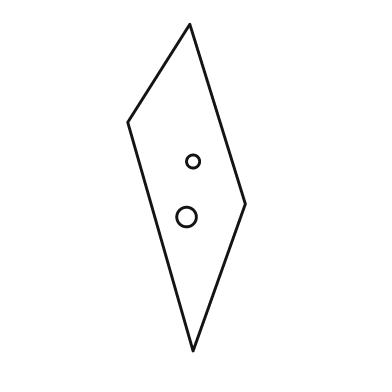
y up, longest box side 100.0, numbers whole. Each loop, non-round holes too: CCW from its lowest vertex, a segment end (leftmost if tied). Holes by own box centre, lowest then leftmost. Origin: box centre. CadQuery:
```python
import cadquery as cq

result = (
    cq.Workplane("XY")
    .moveTo(2.0, -50.0)
    .lineTo(18.0, -5.0)
    .lineTo(1.0, 50.0)
    .lineTo(-18.0, 20.0)
    .close()
    .moveTo(0.0, -9.0)
    .circle(3.0)
    .moveTo(2.0, 8.0)
    .circle(2.0)
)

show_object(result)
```